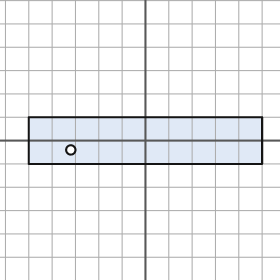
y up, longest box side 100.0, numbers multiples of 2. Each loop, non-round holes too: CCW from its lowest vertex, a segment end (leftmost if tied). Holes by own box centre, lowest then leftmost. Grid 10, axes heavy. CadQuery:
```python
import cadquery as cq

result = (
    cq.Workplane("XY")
    .moveTo(-50.0, -10.0)
    .lineTo(50.0, -10.0)
    .lineTo(50.0, 10.0)
    .lineTo(-50.0, 10.0)
    .close()
    .moveTo(-32.0, -4.0)
    .circle(2.0)
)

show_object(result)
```